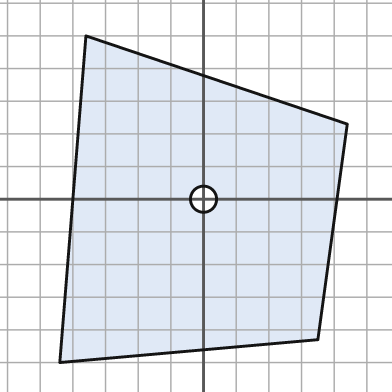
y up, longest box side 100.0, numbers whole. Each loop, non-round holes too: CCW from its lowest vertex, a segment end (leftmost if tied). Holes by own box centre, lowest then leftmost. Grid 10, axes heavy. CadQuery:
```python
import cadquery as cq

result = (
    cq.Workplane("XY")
    .moveTo(-44.0, -50.0)
    .lineTo(35.0, -43.0)
    .lineTo(44.0, 23.0)
    .lineTo(-36.0, 50.0)
    .close()
    .moveTo(0.0, 0.0)
    .circle(4.0)
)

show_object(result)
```